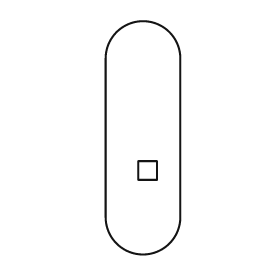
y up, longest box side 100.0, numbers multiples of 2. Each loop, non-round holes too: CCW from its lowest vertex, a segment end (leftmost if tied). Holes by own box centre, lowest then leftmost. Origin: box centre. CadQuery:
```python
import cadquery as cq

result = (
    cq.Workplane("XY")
    .moveTo(-16.0, -34.0)
    .threePointArc((0.0, -50.0), (16.0, -34.0))
    .lineTo(16.0, 34.0)
    .threePointArc((0.0, 50.0), (-16.0, 34.0))
    .close()
    .moveTo(-2.0, -18.0)
    .lineTo(6.0, -18.0)
    .lineTo(6.0, -10.0)
    .lineTo(-2.0, -10.0)
    .close()
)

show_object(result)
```